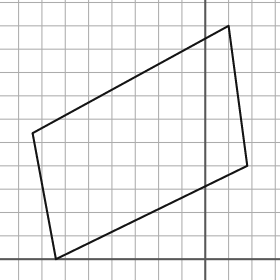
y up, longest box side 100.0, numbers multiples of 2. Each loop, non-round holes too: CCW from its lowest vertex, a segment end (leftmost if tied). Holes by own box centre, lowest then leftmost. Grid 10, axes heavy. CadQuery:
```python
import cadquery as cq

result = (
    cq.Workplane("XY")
    .moveTo(-64.0, 0.0)
    .lineTo(18.0, 40.0)
    .lineTo(10.0, 100.0)
    .lineTo(-74.0, 54.0)
    .close()
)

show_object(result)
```